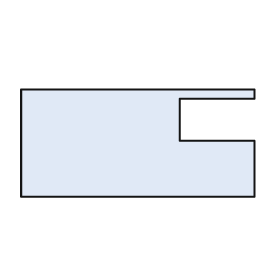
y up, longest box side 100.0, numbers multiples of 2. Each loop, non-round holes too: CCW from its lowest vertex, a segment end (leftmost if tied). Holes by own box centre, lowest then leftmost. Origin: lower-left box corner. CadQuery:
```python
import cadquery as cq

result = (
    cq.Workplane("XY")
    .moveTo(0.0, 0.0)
    .lineTo(100.0, 0.0)
    .lineTo(100.0, 24.0)
    .lineTo(68.0, 24.0)
    .lineTo(68.0, 42.0)
    .lineTo(100.0, 42.0)
    .lineTo(100.0, 46.0)
    .lineTo(0.0, 46.0)
    .close()
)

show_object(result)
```